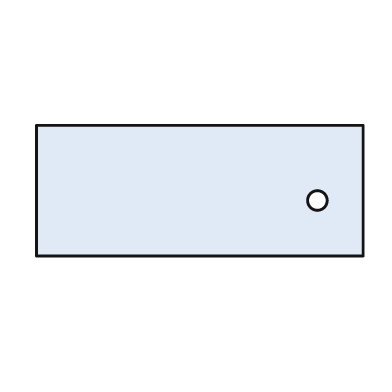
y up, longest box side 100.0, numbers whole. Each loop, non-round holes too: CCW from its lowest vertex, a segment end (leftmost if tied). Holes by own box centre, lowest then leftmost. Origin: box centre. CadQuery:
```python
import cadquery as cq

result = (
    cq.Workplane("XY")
    .moveTo(-50.0, -20.0)
    .lineTo(50.0, -20.0)
    .lineTo(50.0, 20.0)
    .lineTo(-50.0, 20.0)
    .close()
    .moveTo(36.0, -3.0)
    .circle(3.0)
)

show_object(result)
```